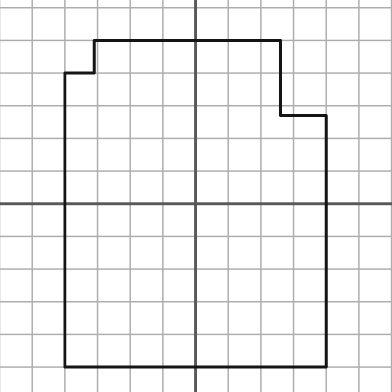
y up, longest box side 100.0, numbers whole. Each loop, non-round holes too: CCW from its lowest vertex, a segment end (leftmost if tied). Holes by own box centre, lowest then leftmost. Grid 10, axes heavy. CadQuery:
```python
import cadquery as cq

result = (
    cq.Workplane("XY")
    .moveTo(-40.0, -50.0)
    .lineTo(40.0, -50.0)
    .lineTo(40.0, 27.0)
    .lineTo(26.0, 27.0)
    .lineTo(26.0, 50.0)
    .lineTo(-31.0, 50.0)
    .lineTo(-31.0, 40.0)
    .lineTo(-40.0, 40.0)
    .close()
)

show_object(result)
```